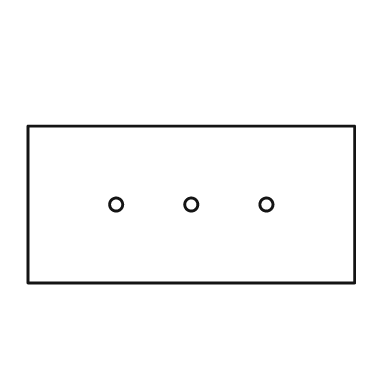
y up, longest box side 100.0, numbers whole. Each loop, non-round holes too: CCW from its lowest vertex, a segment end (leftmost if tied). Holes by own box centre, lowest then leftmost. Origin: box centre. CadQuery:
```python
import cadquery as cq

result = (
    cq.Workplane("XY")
    .moveTo(-50.0, -24.0)
    .lineTo(50.0, -24.0)
    .lineTo(50.0, 24.0)
    .lineTo(-50.0, 24.0)
    .close()
    .moveTo(-23.0, 0.0)
    .circle(2.0)
    .moveTo(0.0, 0.0)
    .circle(2.0)
    .moveTo(23.0, 0.0)
    .circle(2.0)
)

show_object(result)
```